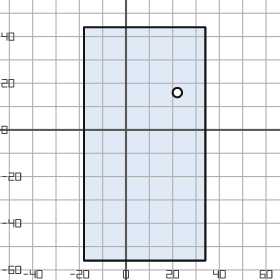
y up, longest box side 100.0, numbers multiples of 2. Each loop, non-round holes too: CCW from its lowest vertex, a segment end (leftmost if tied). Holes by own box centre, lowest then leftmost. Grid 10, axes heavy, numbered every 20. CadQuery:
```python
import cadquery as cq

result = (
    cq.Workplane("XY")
    .moveTo(-18.0, -56.0)
    .lineTo(34.0, -56.0)
    .lineTo(34.0, 44.0)
    .lineTo(-18.0, 44.0)
    .close()
    .moveTo(22.0, 16.0)
    .circle(2.0)
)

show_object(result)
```